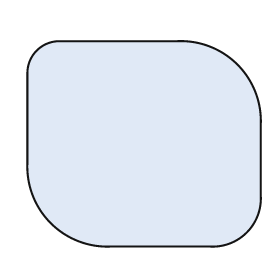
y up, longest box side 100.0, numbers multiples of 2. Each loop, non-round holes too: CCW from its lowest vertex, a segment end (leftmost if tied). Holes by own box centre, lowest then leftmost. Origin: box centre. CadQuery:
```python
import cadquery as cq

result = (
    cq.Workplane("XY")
    .moveTo(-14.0, -44.0)
    .lineTo(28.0, -44.0)
    .threePointArc((44.0, -38.0), (50.0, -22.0))
    .lineTo(50.0, 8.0)
    .threePointArc((40.0, 34.0), (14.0, 44.0))
    .lineTo(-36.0, 44.0)
    .threePointArc((-46.0, 40.0), (-50.0, 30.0))
    .lineTo(-50.0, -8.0)
    .threePointArc((-40.0, -34.0), (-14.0, -44.0))
    .close()
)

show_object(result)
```